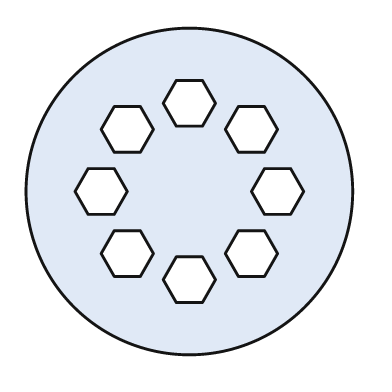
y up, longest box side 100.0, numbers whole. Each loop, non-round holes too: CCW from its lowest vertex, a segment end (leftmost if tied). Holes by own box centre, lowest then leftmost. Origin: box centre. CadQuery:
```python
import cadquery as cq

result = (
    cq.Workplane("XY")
    .moveTo(0.0, 0.0)
    .circle(50.0)
    .moveTo(-4.0, -34.0)
    .lineTo(4.0, -34.0)
    .lineTo(8.0, -27.0)
    .lineTo(4.0, -20.0)
    .lineTo(-4.0, -20.0)
    .lineTo(-8.0, -27.0)
    .close()
    .moveTo(-23.0, -26.0)
    .lineTo(-15.0, -26.0)
    .lineTo(-11.0, -19.0)
    .lineTo(-15.0, -12.0)
    .lineTo(-23.0, -12.0)
    .lineTo(-27.0, -19.0)
    .close()
    .moveTo(15.0, -26.0)
    .lineTo(23.0, -26.0)
    .lineTo(27.0, -19.0)
    .lineTo(23.0, -12.0)
    .lineTo(15.0, -12.0)
    .lineTo(11.0, -19.0)
    .close()
    .moveTo(-31.0, -7.0)
    .lineTo(-23.0, -7.0)
    .lineTo(-19.0, 0.0)
    .lineTo(-23.0, 7.0)
    .lineTo(-31.0, 7.0)
    .lineTo(-35.0, 0.0)
    .close()
    .moveTo(23.0, -7.0)
    .lineTo(31.0, -7.0)
    .lineTo(35.0, 0.0)
    .lineTo(31.0, 7.0)
    .lineTo(23.0, 7.0)
    .lineTo(19.0, 0.0)
    .close()
    .moveTo(-23.0, 12.0)
    .lineTo(-15.0, 12.0)
    .lineTo(-11.0, 19.0)
    .lineTo(-15.0, 26.0)
    .lineTo(-23.0, 26.0)
    .lineTo(-27.0, 19.0)
    .close()
    .moveTo(15.0, 12.0)
    .lineTo(23.0, 12.0)
    .lineTo(27.0, 19.0)
    .lineTo(23.0, 26.0)
    .lineTo(15.0, 26.0)
    .lineTo(11.0, 19.0)
    .close()
    .moveTo(-4.0, 20.0)
    .lineTo(4.0, 20.0)
    .lineTo(8.0, 27.0)
    .lineTo(4.0, 34.0)
    .lineTo(-4.0, 34.0)
    .lineTo(-8.0, 27.0)
    .close()
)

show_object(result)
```